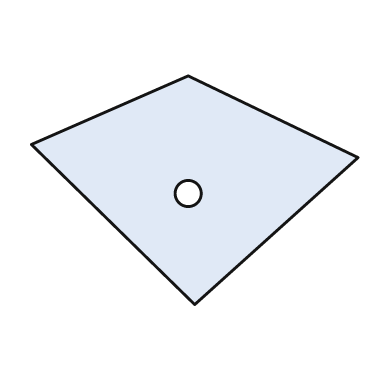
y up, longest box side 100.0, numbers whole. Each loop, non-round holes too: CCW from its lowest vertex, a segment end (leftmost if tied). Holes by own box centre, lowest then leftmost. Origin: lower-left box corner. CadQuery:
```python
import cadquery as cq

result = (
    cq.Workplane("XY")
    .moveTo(50.0, 0.0)
    .lineTo(100.0, 45.0)
    .lineTo(48.0, 70.0)
    .lineTo(0.0, 49.0)
    .close()
    .moveTo(48.0, 34.0)
    .circle(4.0)
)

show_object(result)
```